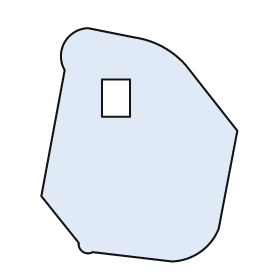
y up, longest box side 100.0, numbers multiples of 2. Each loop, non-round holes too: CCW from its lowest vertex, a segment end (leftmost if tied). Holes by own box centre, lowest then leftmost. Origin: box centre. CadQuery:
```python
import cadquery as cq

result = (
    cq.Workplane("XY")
    .moveTo(14.0, -50.0)
    .threePointArc((26.0, -46.0), (34.0, -36.0))
    .lineTo(42.0, 6.0)
    .lineTo(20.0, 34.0)
    .threePointArc((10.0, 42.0), (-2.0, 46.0))
    .lineTo(-22.0, 50.0)
    .threePointArc((-32.0, 44.0), (-32.0, 32.0))
    .lineTo(-42.0, -22.0)
    .lineTo(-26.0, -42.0)
    .threePointArc((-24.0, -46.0), (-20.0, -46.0))
    .close()
    .moveTo(-16.0, 12.0)
    .lineTo(-4.0, 12.0)
    .lineTo(-4.0, 28.0)
    .lineTo(-16.0, 28.0)
    .close()
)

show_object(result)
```